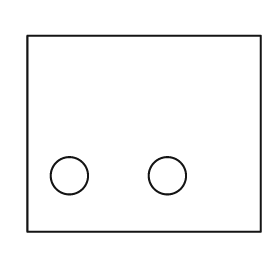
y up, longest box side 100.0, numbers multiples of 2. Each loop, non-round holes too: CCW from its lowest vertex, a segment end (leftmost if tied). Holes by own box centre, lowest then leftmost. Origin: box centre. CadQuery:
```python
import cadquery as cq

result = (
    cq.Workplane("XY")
    .moveTo(-50.0, -42.0)
    .lineTo(50.0, -42.0)
    .lineTo(50.0, 42.0)
    .lineTo(-50.0, 42.0)
    .close()
    .moveTo(-32.0, -18.0)
    .circle(8.0)
    .moveTo(10.0, -18.0)
    .circle(8.0)
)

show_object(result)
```